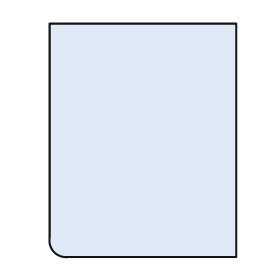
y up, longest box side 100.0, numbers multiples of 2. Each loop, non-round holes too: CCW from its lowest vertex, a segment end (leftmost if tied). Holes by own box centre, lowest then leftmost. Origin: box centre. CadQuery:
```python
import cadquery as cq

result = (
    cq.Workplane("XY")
    .moveTo(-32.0, -50.0)
    .lineTo(40.0, -50.0)
    .lineTo(40.0, 50.0)
    .lineTo(-40.0, 50.0)
    .lineTo(-40.0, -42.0)
    .threePointArc((-38.0, -48.0), (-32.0, -50.0))
    .close()
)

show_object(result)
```